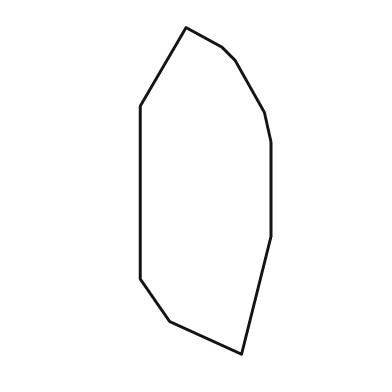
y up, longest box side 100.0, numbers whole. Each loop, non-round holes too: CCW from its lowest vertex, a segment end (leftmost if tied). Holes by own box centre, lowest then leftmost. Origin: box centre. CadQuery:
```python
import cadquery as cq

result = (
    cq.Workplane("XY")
    .moveTo(11.0, -50.0)
    .lineTo(20.0, -14.0)
    .lineTo(20.0, 15.0)
    .lineTo(18.0, 24.0)
    .lineTo(9.0, 40.0)
    .lineTo(5.0, 44.0)
    .lineTo(-6.0, 50.0)
    .lineTo(-20.0, 26.0)
    .lineTo(-20.0, -27.0)
    .lineTo(-11.0, -40.0)
    .close()
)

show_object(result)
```